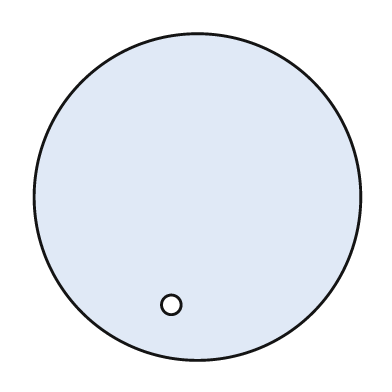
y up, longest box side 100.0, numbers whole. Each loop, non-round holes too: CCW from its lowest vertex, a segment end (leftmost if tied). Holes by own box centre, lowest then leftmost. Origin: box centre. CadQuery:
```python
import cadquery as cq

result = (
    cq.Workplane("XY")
    .moveTo(0.0, 0.0)
    .circle(50.0)
    .moveTo(-8.0, -33.0)
    .circle(3.0)
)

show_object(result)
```